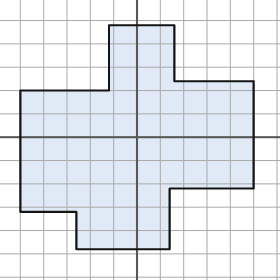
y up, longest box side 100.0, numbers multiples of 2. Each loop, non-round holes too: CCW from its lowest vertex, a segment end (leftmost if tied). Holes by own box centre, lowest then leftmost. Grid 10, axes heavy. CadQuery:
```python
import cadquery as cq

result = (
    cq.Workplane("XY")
    .moveTo(-26.0, -48.0)
    .lineTo(14.0, -48.0)
    .lineTo(14.0, -22.0)
    .lineTo(50.0, -22.0)
    .lineTo(50.0, 24.0)
    .lineTo(16.0, 24.0)
    .lineTo(16.0, 48.0)
    .lineTo(-12.0, 48.0)
    .lineTo(-12.0, 20.0)
    .lineTo(-50.0, 20.0)
    .lineTo(-50.0, -32.0)
    .lineTo(-26.0, -32.0)
    .close()
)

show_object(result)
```